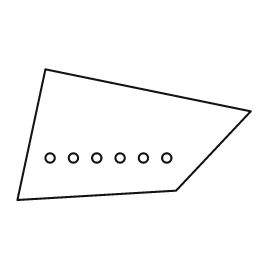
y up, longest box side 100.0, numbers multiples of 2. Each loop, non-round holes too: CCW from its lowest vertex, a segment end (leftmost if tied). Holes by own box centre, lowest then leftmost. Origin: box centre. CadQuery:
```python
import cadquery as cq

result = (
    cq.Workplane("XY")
    .moveTo(-50.0, -28.0)
    .lineTo(18.0, -24.0)
    .lineTo(50.0, 10.0)
    .lineTo(-38.0, 28.0)
    .close()
    .moveTo(-36.0, -10.0)
    .circle(2.0)
    .moveTo(-26.0, -10.0)
    .circle(2.0)
    .moveTo(-16.0, -10.0)
    .circle(2.0)
    .moveTo(-6.0, -10.0)
    .circle(2.0)
    .moveTo(4.0, -10.0)
    .circle(2.0)
    .moveTo(14.0, -10.0)
    .circle(2.0)
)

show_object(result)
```